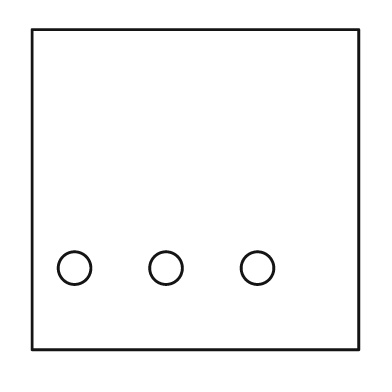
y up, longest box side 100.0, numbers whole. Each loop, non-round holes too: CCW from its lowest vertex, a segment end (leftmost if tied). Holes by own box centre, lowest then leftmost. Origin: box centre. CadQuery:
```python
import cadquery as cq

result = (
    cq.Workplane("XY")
    .moveTo(-50.0, -49.0)
    .lineTo(50.0, -49.0)
    .lineTo(50.0, 49.0)
    .lineTo(-50.0, 49.0)
    .close()
    .moveTo(-37.0, -24.0)
    .circle(5.0)
    .moveTo(-9.0, -24.0)
    .circle(5.0)
    .moveTo(19.0, -24.0)
    .circle(5.0)
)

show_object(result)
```